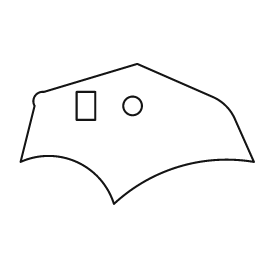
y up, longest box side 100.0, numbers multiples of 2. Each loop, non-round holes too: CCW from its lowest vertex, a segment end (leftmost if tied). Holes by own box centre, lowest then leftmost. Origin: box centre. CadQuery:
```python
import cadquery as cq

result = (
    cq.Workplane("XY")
    .moveTo(-10.0, -30.0)
    .threePointArc((18.0, -14.0), (50.0, -12.0))
    .lineTo(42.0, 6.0)
    .threePointArc((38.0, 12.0), (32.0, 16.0))
    .lineTo(0.0, 30.0)
    .lineTo(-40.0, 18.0)
    .threePointArc((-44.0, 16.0), (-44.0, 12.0))
    .lineTo(-50.0, -12.0)
    .threePointArc((-26.0, -12.0), (-10.0, -30.0))
    .close()
    .moveTo(-26.0, 6.0)
    .lineTo(-18.0, 6.0)
    .lineTo(-18.0, 18.0)
    .lineTo(-26.0, 18.0)
    .close()
    .moveTo(-2.0, 12.0)
    .circle(4.0)
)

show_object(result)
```